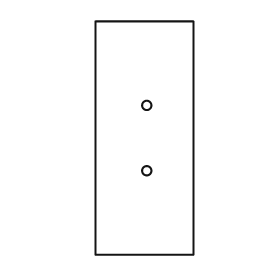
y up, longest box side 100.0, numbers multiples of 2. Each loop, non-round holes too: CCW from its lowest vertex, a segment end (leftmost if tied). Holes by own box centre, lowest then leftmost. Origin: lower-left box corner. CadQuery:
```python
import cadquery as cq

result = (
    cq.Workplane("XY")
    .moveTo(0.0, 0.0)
    .lineTo(42.0, 0.0)
    .lineTo(42.0, 100.0)
    .lineTo(0.0, 100.0)
    .close()
    .moveTo(22.0, 36.0)
    .circle(2.0)
    .moveTo(22.0, 64.0)
    .circle(2.0)
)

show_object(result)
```